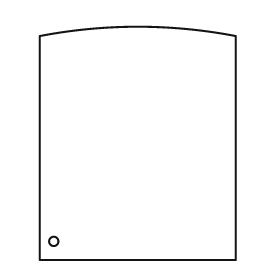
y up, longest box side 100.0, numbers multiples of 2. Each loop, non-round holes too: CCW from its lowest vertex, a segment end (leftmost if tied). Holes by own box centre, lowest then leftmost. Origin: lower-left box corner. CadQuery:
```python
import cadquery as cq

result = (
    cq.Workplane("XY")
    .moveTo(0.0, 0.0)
    .lineTo(84.0, 0.0)
    .lineTo(84.0, 96.0)
    .threePointArc((42.0, 100.0), (0.0, 96.0))
    .close()
    .moveTo(6.0, 8.0)
    .circle(2.0)
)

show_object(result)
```